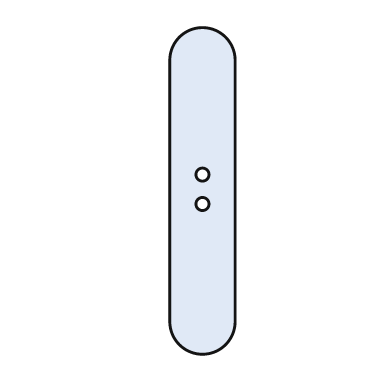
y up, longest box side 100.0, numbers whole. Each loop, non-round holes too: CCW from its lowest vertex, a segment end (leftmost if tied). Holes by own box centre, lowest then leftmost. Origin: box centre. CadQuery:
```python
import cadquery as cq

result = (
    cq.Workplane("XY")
    .moveTo(-10.0, -40.0)
    .threePointArc((0.0, -50.0), (10.0, -40.0))
    .lineTo(10.0, 40.0)
    .threePointArc((0.0, 50.0), (-10.0, 40.0))
    .close()
    .moveTo(0.0, -4.0)
    .circle(2.0)
    .moveTo(0.0, 5.0)
    .circle(2.0)
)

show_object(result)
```